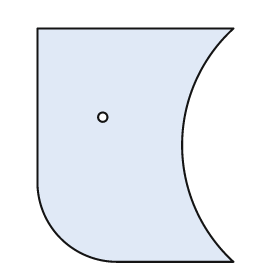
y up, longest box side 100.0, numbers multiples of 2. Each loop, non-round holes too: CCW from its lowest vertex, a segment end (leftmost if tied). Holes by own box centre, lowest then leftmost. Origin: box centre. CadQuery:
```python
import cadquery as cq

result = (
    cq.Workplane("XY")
    .moveTo(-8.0, -50.0)
    .lineTo(42.0, -50.0)
    .threePointArc((20.0, 0.0), (42.0, 50.0))
    .lineTo(-42.0, 50.0)
    .lineTo(-42.0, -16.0)
    .threePointArc((-32.0, -40.0), (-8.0, -50.0))
    .close()
    .moveTo(-14.0, 12.0)
    .circle(2.0)
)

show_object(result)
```